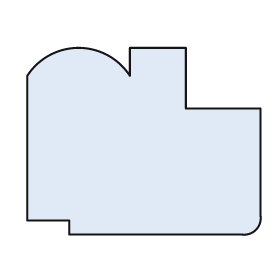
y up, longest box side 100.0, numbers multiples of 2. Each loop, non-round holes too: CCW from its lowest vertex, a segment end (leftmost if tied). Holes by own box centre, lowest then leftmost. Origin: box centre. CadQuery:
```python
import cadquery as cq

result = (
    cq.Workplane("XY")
    .moveTo(-32.0, -40.0)
    .lineTo(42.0, -40.0)
    .threePointArc((48.0, -38.0), (50.0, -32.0))
    .lineTo(50.0, 14.0)
    .lineTo(18.0, 14.0)
    .lineTo(18.0, 40.0)
    .lineTo(-6.0, 40.0)
    .lineTo(-6.0, 28.0)
    .threePointArc((-28.0, 40.0), (-50.0, 28.0))
    .lineTo(-50.0, -34.0)
    .lineTo(-32.0, -34.0)
    .close()
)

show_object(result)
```